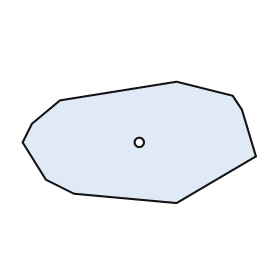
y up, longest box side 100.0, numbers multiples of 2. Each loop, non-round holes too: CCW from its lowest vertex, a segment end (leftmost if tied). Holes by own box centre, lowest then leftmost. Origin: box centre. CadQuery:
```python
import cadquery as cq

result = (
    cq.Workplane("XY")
    .moveTo(16.0, -26.0)
    .lineTo(50.0, -6.0)
    .lineTo(44.0, 14.0)
    .lineTo(40.0, 20.0)
    .lineTo(16.0, 26.0)
    .lineTo(-34.0, 18.0)
    .lineTo(-46.0, 8.0)
    .lineTo(-50.0, 0.0)
    .lineTo(-40.0, -16.0)
    .lineTo(-28.0, -22.0)
    .close()
    .moveTo(0.0, 0.0)
    .circle(2.0)
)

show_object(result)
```